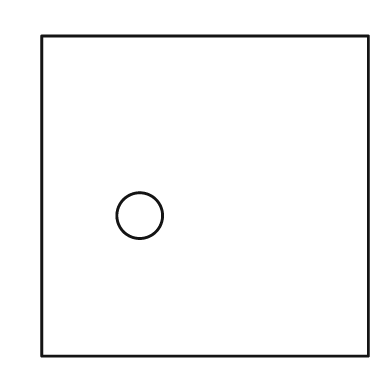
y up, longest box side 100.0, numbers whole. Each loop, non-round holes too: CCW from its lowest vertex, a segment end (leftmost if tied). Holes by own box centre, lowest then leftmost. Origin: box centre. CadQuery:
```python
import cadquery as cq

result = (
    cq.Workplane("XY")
    .moveTo(-50.0, -49.0)
    .lineTo(50.0, -49.0)
    .lineTo(50.0, 49.0)
    .lineTo(-50.0, 49.0)
    .close()
    .moveTo(-20.0, -6.0)
    .circle(7.0)
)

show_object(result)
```